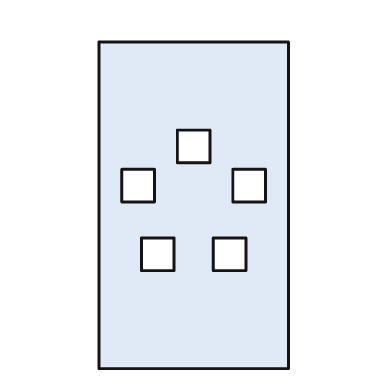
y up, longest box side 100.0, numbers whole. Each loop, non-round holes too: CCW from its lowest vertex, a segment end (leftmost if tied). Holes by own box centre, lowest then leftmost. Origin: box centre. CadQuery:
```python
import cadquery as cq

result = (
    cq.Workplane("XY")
    .moveTo(-29.0, -50.0)
    .lineTo(29.0, -50.0)
    .lineTo(29.0, 50.0)
    .lineTo(-29.0, 50.0)
    .close()
    .moveTo(-16.0, -20.0)
    .lineTo(-6.0, -20.0)
    .lineTo(-6.0, -10.0)
    .lineTo(-16.0, -10.0)
    .close()
    .moveTo(6.0, -20.0)
    .lineTo(16.0, -20.0)
    .lineTo(16.0, -10.0)
    .lineTo(6.0, -10.0)
    .close()
    .moveTo(-22.0, 1.0)
    .lineTo(-12.0, 1.0)
    .lineTo(-12.0, 11.0)
    .lineTo(-22.0, 11.0)
    .close()
    .moveTo(12.0, 1.0)
    .lineTo(22.0, 1.0)
    .lineTo(22.0, 11.0)
    .lineTo(12.0, 11.0)
    .close()
    .moveTo(-5.0, 13.0)
    .lineTo(5.0, 13.0)
    .lineTo(5.0, 23.0)
    .lineTo(-5.0, 23.0)
    .close()
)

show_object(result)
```